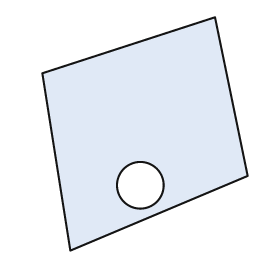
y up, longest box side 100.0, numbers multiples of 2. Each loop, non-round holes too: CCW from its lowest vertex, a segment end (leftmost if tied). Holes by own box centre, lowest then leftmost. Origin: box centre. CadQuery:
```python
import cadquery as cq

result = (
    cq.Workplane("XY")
    .moveTo(-32.0, -50.0)
    .lineTo(44.0, -18.0)
    .lineTo(30.0, 50.0)
    .lineTo(-44.0, 26.0)
    .close()
    .moveTo(-2.0, -22.0)
    .circle(10.0)
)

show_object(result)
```